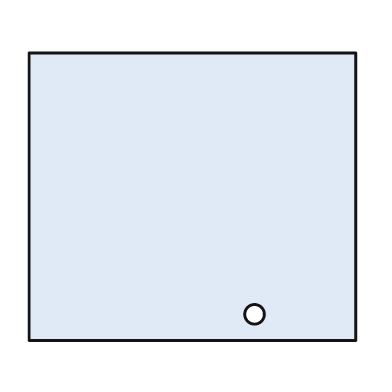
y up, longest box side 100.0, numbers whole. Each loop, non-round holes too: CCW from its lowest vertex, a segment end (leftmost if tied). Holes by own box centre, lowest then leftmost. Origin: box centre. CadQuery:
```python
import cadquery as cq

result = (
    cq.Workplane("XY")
    .moveTo(-50.0, -44.0)
    .lineTo(50.0, -44.0)
    .lineTo(50.0, 44.0)
    .lineTo(-50.0, 44.0)
    .close()
    .moveTo(19.0, -36.0)
    .circle(3.0)
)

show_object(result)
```